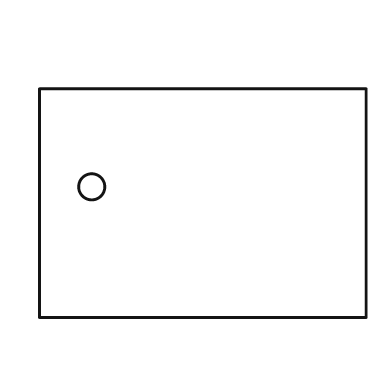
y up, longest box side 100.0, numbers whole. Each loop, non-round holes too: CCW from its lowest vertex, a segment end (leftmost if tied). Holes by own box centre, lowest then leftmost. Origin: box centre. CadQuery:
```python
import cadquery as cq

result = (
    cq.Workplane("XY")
    .moveTo(-50.0, -35.0)
    .lineTo(50.0, -35.0)
    .lineTo(50.0, 35.0)
    .lineTo(-50.0, 35.0)
    .close()
    .moveTo(-34.0, 5.0)
    .circle(4.0)
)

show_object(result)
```